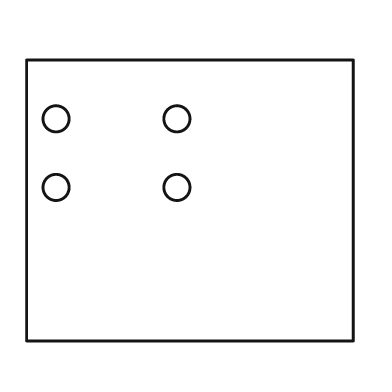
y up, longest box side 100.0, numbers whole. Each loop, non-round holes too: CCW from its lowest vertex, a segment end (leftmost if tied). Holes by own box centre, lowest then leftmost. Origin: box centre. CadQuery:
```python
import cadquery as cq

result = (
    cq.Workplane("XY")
    .moveTo(-50.0, -43.0)
    .lineTo(50.0, -43.0)
    .lineTo(50.0, 43.0)
    .lineTo(-50.0, 43.0)
    .close()
    .moveTo(-41.0, 4.0)
    .circle(4.0)
    .moveTo(-4.0, 4.0)
    .circle(4.0)
    .moveTo(-41.0, 25.0)
    .circle(4.0)
    .moveTo(-4.0, 25.0)
    .circle(4.0)
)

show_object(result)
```